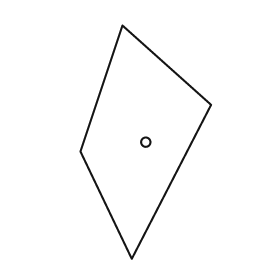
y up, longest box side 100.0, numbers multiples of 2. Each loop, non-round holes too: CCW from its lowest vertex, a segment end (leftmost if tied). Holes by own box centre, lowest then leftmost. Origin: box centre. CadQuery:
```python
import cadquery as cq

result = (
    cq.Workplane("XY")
    .moveTo(-6.0, -50.0)
    .lineTo(28.0, 16.0)
    .lineTo(-10.0, 50.0)
    .lineTo(-28.0, -4.0)
    .close()
    .moveTo(0.0, 0.0)
    .circle(2.0)
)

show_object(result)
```